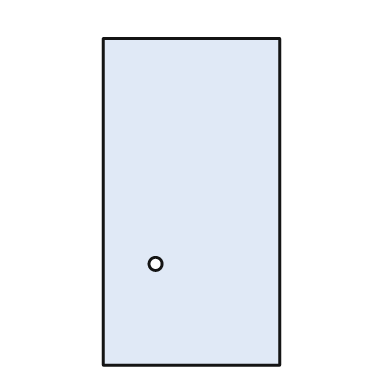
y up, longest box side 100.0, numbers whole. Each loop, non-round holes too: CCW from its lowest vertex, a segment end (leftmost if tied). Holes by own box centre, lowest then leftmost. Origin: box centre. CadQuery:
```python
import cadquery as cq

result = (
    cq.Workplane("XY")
    .moveTo(-27.0, -50.0)
    .lineTo(27.0, -50.0)
    .lineTo(27.0, 50.0)
    .lineTo(-27.0, 50.0)
    .close()
    .moveTo(-11.0, -19.0)
    .circle(2.0)
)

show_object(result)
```